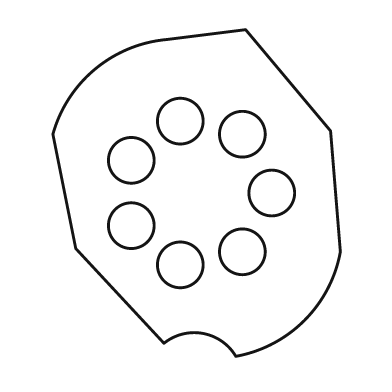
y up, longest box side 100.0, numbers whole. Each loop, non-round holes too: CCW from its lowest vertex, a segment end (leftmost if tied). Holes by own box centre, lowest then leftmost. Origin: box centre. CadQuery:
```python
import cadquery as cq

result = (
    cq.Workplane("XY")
    .moveTo(12.0, -50.0)
    .threePointArc((33.0, -39.0), (44.0, -18.0))
    .lineTo(41.0, 19.0)
    .lineTo(15.0, 50.0)
    .lineTo(-9.0, 47.0)
    .threePointArc((-31.0, 38.0), (-44.0, 18.0))
    .lineTo(-37.0, -17.0)
    .lineTo(-10.0, -46.0)
    .threePointArc((2.0, -43.0), (12.0, -50.0))
    .close()
    .moveTo(-5.0, -22.0)
    .circle(7.0)
    .moveTo(14.0, -18.0)
    .circle(7.0)
    .moveTo(-20.0, -10.0)
    .circle(7.0)
    .moveTo(23.0, 0.0)
    .circle(7.0)
    .moveTo(-20.0, 10.0)
    .circle(7.0)
    .moveTo(14.0, 18.0)
    .circle(7.0)
    .moveTo(-5.0, 22.0)
    .circle(7.0)
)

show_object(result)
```